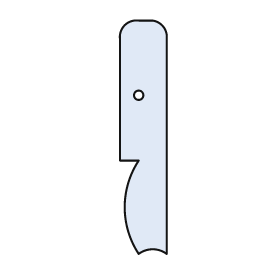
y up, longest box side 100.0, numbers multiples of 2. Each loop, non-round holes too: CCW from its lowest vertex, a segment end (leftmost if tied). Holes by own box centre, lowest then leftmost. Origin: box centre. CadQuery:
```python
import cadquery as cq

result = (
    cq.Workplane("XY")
    .moveTo(-2.0, -50.0)
    .threePointArc((4.0, -48.0), (10.0, -50.0))
    .lineTo(10.0, 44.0)
    .threePointArc((8.0, 48.0), (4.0, 50.0))
    .lineTo(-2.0, 50.0)
    .threePointArc((-8.0, 48.0), (-10.0, 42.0))
    .lineTo(-10.0, -10.0)
    .lineTo(-2.0, -10.0)
    .threePointArc((-8.0, -30.0), (-2.0, -50.0))
    .close()
    .moveTo(-2.0, 18.0)
    .circle(2.0)
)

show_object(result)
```